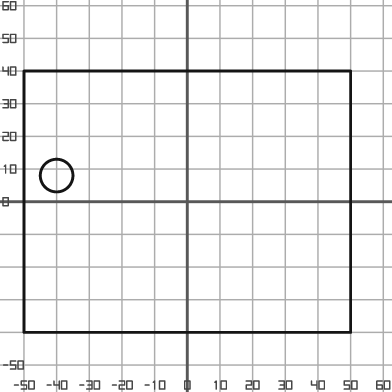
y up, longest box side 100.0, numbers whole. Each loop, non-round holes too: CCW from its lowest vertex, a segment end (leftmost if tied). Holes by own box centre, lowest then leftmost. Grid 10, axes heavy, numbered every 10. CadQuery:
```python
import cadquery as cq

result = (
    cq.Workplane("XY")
    .moveTo(-50.0, -40.0)
    .lineTo(50.0, -40.0)
    .lineTo(50.0, 40.0)
    .lineTo(-50.0, 40.0)
    .close()
    .moveTo(-40.0, 8.0)
    .circle(5.0)
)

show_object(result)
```